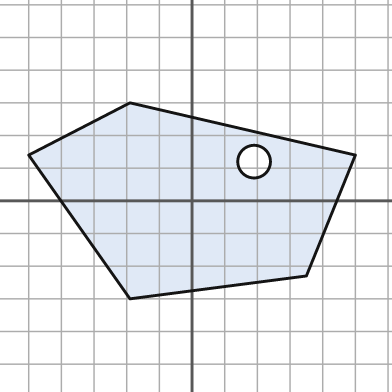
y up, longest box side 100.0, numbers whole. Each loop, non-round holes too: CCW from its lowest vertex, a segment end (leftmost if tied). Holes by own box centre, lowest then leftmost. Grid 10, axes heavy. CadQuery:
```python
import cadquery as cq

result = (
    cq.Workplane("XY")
    .moveTo(-19.0, -30.0)
    .lineTo(35.0, -23.0)
    .lineTo(50.0, 14.0)
    .lineTo(-19.0, 30.0)
    .lineTo(-50.0, 14.0)
    .close()
    .moveTo(19.0, 12.0)
    .circle(5.0)
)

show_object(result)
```